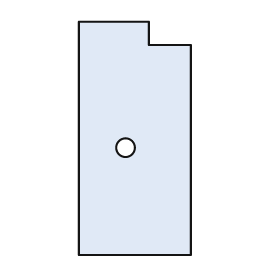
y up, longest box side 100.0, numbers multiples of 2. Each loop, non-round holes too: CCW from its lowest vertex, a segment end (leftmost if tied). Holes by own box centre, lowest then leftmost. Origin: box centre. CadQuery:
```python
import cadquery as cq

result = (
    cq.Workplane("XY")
    .moveTo(-24.0, -50.0)
    .lineTo(24.0, -50.0)
    .lineTo(24.0, 40.0)
    .lineTo(6.0, 40.0)
    .lineTo(6.0, 50.0)
    .lineTo(-24.0, 50.0)
    .close()
    .moveTo(-4.0, -4.0)
    .circle(4.0)
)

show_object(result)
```